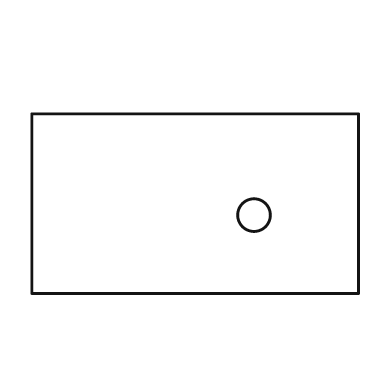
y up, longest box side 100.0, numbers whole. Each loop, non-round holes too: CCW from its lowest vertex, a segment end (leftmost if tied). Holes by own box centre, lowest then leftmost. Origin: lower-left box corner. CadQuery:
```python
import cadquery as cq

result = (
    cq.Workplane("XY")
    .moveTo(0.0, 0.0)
    .lineTo(100.0, 0.0)
    .lineTo(100.0, 55.0)
    .lineTo(0.0, 55.0)
    .close()
    .moveTo(68.0, 24.0)
    .circle(5.0)
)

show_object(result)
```